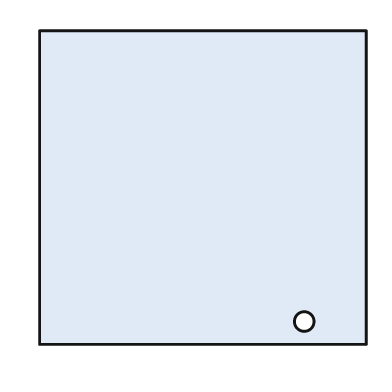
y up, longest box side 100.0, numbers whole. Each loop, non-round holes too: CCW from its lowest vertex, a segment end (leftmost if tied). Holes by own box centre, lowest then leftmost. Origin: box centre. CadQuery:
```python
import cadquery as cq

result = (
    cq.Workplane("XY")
    .moveTo(-50.0, -48.0)
    .lineTo(50.0, -48.0)
    .lineTo(50.0, 48.0)
    .lineTo(-50.0, 48.0)
    .close()
    .moveTo(31.0, -41.0)
    .circle(3.0)
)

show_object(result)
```